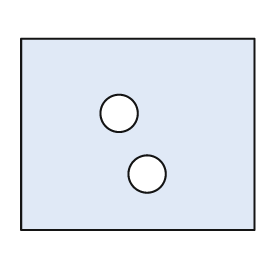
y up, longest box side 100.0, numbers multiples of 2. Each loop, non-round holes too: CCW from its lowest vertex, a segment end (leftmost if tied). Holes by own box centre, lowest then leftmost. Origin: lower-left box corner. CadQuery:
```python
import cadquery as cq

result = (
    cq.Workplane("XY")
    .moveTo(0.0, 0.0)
    .lineTo(100.0, 0.0)
    .lineTo(100.0, 82.0)
    .lineTo(0.0, 82.0)
    .close()
    .moveTo(54.0, 24.0)
    .circle(8.0)
    .moveTo(42.0, 50.0)
    .circle(8.0)
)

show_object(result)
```